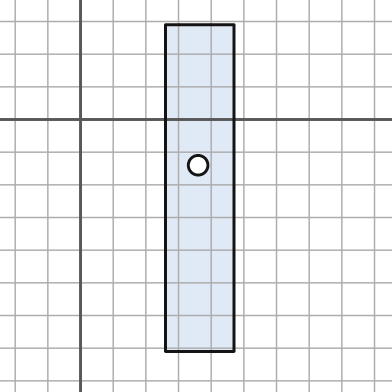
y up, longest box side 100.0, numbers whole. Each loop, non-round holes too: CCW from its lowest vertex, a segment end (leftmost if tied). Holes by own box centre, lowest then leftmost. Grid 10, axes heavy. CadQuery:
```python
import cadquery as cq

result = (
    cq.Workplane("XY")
    .moveTo(26.0, -71.0)
    .lineTo(47.0, -71.0)
    .lineTo(47.0, 29.0)
    .lineTo(26.0, 29.0)
    .close()
    .moveTo(36.0, -14.0)
    .circle(3.0)
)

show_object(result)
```